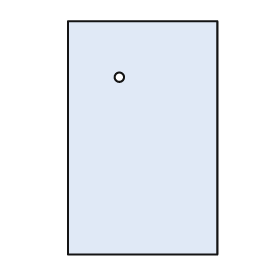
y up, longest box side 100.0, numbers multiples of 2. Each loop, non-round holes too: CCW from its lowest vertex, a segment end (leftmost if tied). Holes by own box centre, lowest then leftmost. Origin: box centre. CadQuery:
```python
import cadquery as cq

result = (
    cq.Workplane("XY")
    .moveTo(-32.0, -50.0)
    .lineTo(32.0, -50.0)
    .lineTo(32.0, 50.0)
    .lineTo(-32.0, 50.0)
    .close()
    .moveTo(-10.0, 26.0)
    .circle(2.0)
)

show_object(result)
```